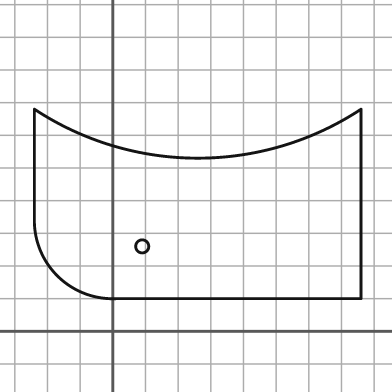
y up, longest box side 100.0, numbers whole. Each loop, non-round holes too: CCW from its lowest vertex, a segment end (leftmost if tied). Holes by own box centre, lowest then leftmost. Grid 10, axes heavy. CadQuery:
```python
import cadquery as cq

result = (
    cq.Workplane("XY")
    .moveTo(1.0, 10.0)
    .lineTo(76.0, 10.0)
    .lineTo(76.0, 68.0)
    .threePointArc((26.0, 53.0), (-24.0, 68.0))
    .lineTo(-24.0, 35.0)
    .threePointArc((-17.0, 17.0), (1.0, 10.0))
    .close()
    .moveTo(9.0, 26.0)
    .circle(2.0)
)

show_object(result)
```